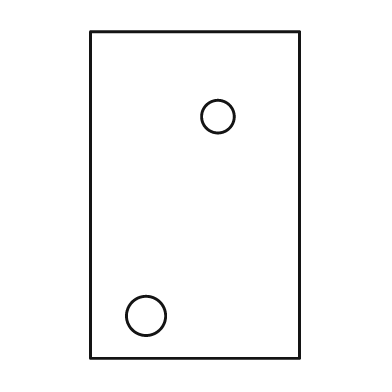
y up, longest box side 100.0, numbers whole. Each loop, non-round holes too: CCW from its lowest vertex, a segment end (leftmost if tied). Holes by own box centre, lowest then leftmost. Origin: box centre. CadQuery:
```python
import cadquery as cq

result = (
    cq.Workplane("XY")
    .moveTo(-32.0, -50.0)
    .lineTo(32.0, -50.0)
    .lineTo(32.0, 50.0)
    .lineTo(-32.0, 50.0)
    .close()
    .moveTo(-15.0, -37.0)
    .circle(6.0)
    .moveTo(7.0, 24.0)
    .circle(5.0)
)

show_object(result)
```